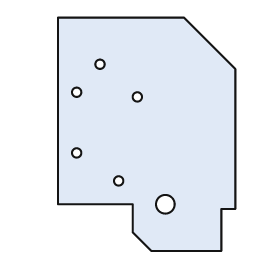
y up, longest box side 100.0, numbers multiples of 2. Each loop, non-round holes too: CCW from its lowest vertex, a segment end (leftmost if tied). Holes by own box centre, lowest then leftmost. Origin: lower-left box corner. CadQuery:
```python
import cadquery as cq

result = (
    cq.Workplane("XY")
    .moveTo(40.0, 0.0)
    .lineTo(70.0, 0.0)
    .lineTo(70.0, 18.0)
    .lineTo(76.0, 18.0)
    .lineTo(76.0, 78.0)
    .lineTo(54.0, 100.0)
    .lineTo(0.0, 100.0)
    .lineTo(0.0, 20.0)
    .lineTo(32.0, 20.0)
    .lineTo(32.0, 8.0)
    .close()
    .moveTo(46.0, 20.0)
    .circle(4.0)
    .moveTo(26.0, 30.0)
    .circle(2.0)
    .moveTo(8.0, 42.0)
    .circle(2.0)
    .moveTo(34.0, 66.0)
    .circle(2.0)
    .moveTo(8.0, 68.0)
    .circle(2.0)
    .moveTo(18.0, 80.0)
    .circle(2.0)
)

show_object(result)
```